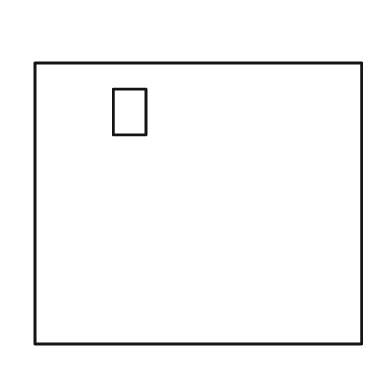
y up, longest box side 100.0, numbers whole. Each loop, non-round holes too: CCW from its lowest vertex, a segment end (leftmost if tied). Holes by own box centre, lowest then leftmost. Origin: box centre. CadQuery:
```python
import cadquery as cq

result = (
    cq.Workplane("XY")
    .moveTo(-50.0, -43.0)
    .lineTo(50.0, -43.0)
    .lineTo(50.0, 43.0)
    .lineTo(-50.0, 43.0)
    .close()
    .moveTo(-26.0, 21.0)
    .lineTo(-16.0, 21.0)
    .lineTo(-16.0, 35.0)
    .lineTo(-26.0, 35.0)
    .close()
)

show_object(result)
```